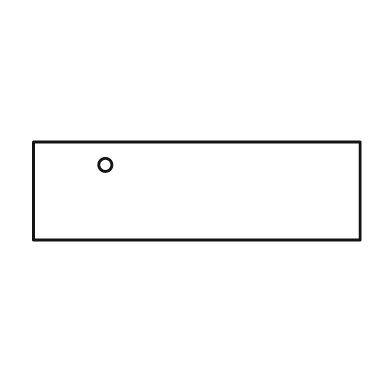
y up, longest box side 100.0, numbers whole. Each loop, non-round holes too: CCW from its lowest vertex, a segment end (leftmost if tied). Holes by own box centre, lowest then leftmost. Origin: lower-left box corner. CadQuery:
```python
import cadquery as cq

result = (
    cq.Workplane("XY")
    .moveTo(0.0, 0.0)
    .lineTo(100.0, 0.0)
    .lineTo(100.0, 30.0)
    .lineTo(0.0, 30.0)
    .close()
    .moveTo(22.0, 23.0)
    .circle(2.0)
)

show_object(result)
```